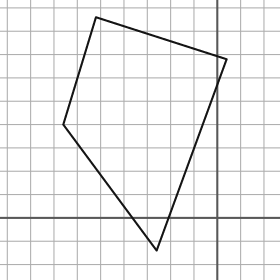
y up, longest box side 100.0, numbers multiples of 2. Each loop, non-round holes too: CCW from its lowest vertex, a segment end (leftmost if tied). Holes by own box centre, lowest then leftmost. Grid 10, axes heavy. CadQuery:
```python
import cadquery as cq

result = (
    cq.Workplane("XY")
    .moveTo(-26.0, -14.0)
    .lineTo(4.0, 68.0)
    .lineTo(-52.0, 86.0)
    .lineTo(-66.0, 40.0)
    .close()
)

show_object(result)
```